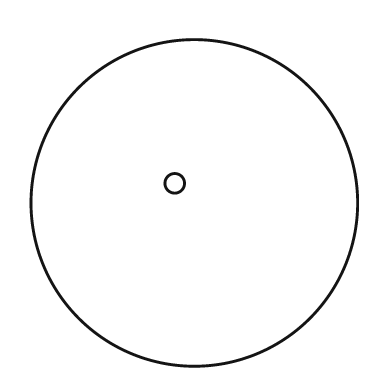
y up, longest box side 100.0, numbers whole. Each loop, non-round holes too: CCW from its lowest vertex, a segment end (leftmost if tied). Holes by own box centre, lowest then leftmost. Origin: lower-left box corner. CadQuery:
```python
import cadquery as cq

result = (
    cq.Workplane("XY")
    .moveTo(50.0, 50.0)
    .circle(50.0)
    .moveTo(44.0, 56.0)
    .circle(3.0)
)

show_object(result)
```